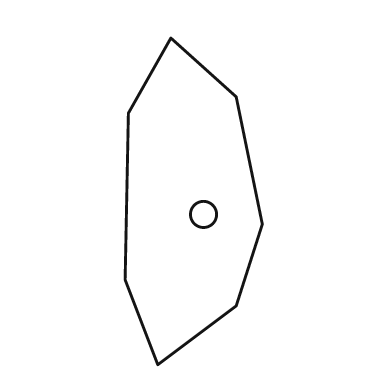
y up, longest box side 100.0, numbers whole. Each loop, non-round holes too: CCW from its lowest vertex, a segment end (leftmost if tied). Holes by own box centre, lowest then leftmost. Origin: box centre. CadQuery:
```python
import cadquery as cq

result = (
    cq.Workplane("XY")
    .moveTo(-11.0, -50.0)
    .lineTo(13.0, -32.0)
    .lineTo(21.0, -7.0)
    .lineTo(13.0, 32.0)
    .lineTo(-7.0, 50.0)
    .lineTo(-20.0, 27.0)
    .lineTo(-21.0, -24.0)
    .close()
    .moveTo(3.0, -4.0)
    .circle(4.0)
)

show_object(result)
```